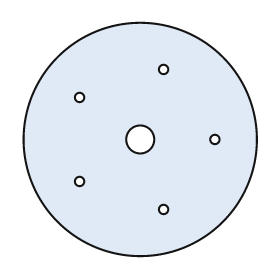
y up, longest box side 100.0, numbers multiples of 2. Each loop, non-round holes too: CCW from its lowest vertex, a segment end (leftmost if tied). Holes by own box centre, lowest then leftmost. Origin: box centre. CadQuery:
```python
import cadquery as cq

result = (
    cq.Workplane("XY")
    .moveTo(0.0, 0.0)
    .circle(50.0)
    .moveTo(10.0, -30.0)
    .circle(2.0)
    .moveTo(-26.0, -18.0)
    .circle(2.0)
    .moveTo(0.0, 0.0)
    .circle(6.0)
    .moveTo(32.0, 0.0)
    .circle(2.0)
    .moveTo(-26.0, 18.0)
    .circle(2.0)
    .moveTo(10.0, 30.0)
    .circle(2.0)
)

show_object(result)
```